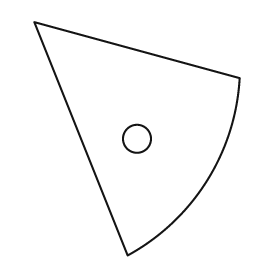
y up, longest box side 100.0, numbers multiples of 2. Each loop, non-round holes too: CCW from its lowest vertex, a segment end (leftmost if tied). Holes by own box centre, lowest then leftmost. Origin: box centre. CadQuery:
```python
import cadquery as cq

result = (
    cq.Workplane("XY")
    .moveTo(-4.0, -50.0)
    .threePointArc((30.0, -18.0), (44.0, 26.0))
    .lineTo(-44.0, 50.0)
    .close()
    .moveTo(0.0, 0.0)
    .circle(6.0)
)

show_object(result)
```